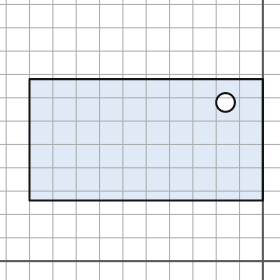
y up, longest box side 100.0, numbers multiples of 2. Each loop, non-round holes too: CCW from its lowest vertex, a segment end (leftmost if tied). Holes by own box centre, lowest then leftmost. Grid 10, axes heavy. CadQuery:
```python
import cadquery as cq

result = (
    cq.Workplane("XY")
    .moveTo(-100.0, 26.0)
    .lineTo(0.0, 26.0)
    .lineTo(0.0, 78.0)
    .lineTo(-100.0, 78.0)
    .close()
    .moveTo(-16.0, 68.0)
    .circle(4.0)
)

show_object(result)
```